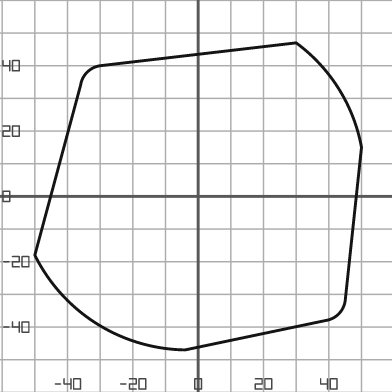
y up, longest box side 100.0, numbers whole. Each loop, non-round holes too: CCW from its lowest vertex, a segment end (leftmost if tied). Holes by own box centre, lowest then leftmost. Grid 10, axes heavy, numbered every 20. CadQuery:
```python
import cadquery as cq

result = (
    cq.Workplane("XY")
    .moveTo(-4.0, -47.0)
    .lineTo(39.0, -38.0)
    .threePointArc((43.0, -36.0), (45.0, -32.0))
    .lineTo(50.0, 15.0)
    .threePointArc((43.0, 33.0), (30.0, 47.0))
    .lineTo(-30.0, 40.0)
    .threePointArc((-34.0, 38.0), (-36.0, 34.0))
    .lineTo(-50.0, -18.0)
    .threePointArc((-31.0, -39.0), (-4.0, -47.0))
    .close()
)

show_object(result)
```